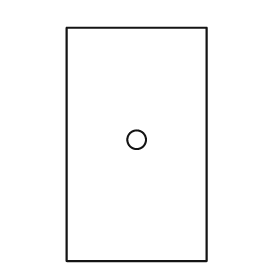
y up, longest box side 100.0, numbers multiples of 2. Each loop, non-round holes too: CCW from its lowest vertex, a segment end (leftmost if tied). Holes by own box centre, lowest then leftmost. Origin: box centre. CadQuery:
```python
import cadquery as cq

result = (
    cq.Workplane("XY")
    .moveTo(-30.0, -50.0)
    .lineTo(30.0, -50.0)
    .lineTo(30.0, 50.0)
    .lineTo(-30.0, 50.0)
    .close()
    .moveTo(0.0, 2.0)
    .circle(4.0)
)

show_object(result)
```